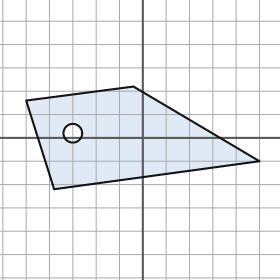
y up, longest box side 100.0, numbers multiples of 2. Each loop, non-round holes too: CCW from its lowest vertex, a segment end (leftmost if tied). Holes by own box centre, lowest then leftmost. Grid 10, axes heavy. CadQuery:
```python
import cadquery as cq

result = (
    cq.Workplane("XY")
    .moveTo(-38.0, -22.0)
    .lineTo(50.0, -10.0)
    .lineTo(-4.0, 22.0)
    .lineTo(-50.0, 16.0)
    .close()
    .moveTo(-30.0, 2.0)
    .circle(4.0)
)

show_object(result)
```